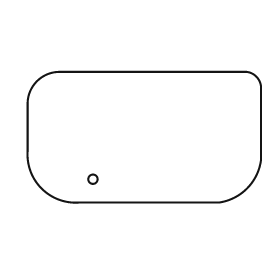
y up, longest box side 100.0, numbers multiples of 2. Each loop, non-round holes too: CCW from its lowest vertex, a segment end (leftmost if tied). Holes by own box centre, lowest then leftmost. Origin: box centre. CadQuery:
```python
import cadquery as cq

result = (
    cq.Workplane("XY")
    .moveTo(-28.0, -28.0)
    .lineTo(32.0, -28.0)
    .threePointArc((44.0, -22.0), (50.0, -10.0))
    .lineTo(50.0, 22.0)
    .threePointArc((48.0, 26.0), (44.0, 28.0))
    .lineTo(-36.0, 28.0)
    .threePointArc((-46.0, 24.0), (-50.0, 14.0))
    .lineTo(-50.0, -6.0)
    .threePointArc((-44.0, -22.0), (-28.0, -28.0))
    .close()
    .moveTo(-22.0, -18.0)
    .circle(2.0)
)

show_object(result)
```